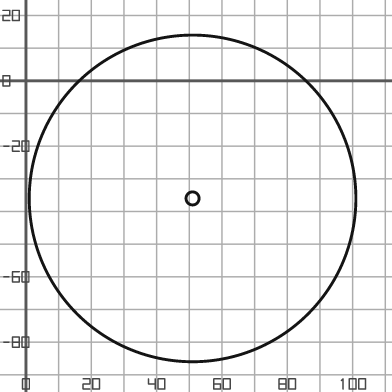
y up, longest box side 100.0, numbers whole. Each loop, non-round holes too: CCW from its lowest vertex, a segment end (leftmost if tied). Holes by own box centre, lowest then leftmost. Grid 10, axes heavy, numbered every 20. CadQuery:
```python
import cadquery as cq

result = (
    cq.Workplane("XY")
    .moveTo(51.0, -36.0)
    .circle(50.0)
    .moveTo(51.0, -36.0)
    .circle(2.0)
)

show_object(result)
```